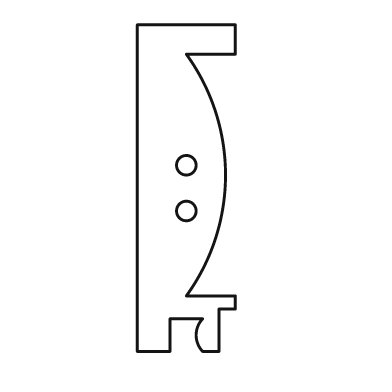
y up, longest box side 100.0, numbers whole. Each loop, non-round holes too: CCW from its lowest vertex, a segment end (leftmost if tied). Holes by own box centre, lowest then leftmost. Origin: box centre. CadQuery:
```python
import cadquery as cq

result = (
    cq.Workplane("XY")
    .moveTo(-15.0, -50.0)
    .lineTo(-5.0, -50.0)
    .lineTo(-5.0, -40.0)
    .lineTo(5.0, -40.0)
    .threePointArc((3.0, -45.0), (5.0, -50.0))
    .lineTo(10.0, -50.0)
    .lineTo(10.0, -37.0)
    .lineTo(15.0, -37.0)
    .lineTo(15.0, -33.0)
    .lineTo(0.0, -33.0)
    .threePointArc((12.0, 4.0), (0.0, 41.0))
    .lineTo(15.0, 41.0)
    .lineTo(15.0, 50.0)
    .lineTo(-15.0, 50.0)
    .close()
    .moveTo(0.0, -7.0)
    .circle(3.0)
    .moveTo(0.0, 7.0)
    .circle(3.0)
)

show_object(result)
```